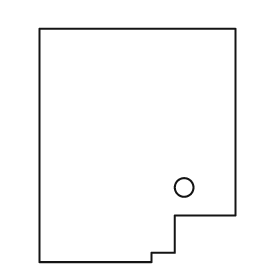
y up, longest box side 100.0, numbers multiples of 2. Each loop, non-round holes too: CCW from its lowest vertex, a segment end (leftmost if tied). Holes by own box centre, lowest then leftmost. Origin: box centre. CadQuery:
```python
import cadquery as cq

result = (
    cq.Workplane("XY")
    .moveTo(-42.0, -50.0)
    .lineTo(6.0, -50.0)
    .lineTo(6.0, -46.0)
    .lineTo(16.0, -46.0)
    .lineTo(16.0, -30.0)
    .lineTo(42.0, -30.0)
    .lineTo(42.0, 50.0)
    .lineTo(-42.0, 50.0)
    .close()
    .moveTo(20.0, -18.0)
    .circle(4.0)
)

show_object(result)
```